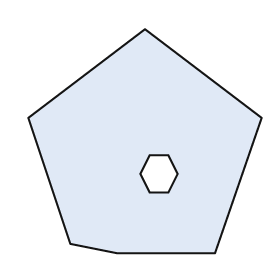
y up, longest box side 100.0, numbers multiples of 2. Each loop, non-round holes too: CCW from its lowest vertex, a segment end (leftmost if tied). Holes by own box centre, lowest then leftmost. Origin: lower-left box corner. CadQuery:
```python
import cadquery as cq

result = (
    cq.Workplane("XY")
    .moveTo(38.0, 0.0)
    .lineTo(80.0, 0.0)
    .lineTo(100.0, 58.0)
    .lineTo(50.0, 96.0)
    .lineTo(0.0, 58.0)
    .lineTo(18.0, 4.0)
    .close()
    .moveTo(52.0, 26.0)
    .lineTo(60.0, 26.0)
    .lineTo(64.0, 34.0)
    .lineTo(60.0, 42.0)
    .lineTo(52.0, 42.0)
    .lineTo(48.0, 34.0)
    .close()
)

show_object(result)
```